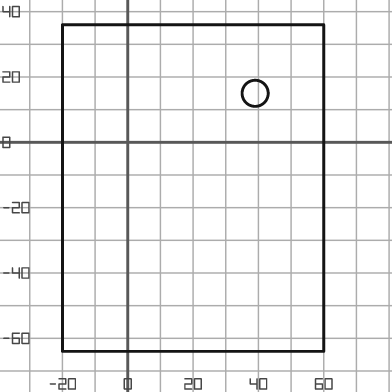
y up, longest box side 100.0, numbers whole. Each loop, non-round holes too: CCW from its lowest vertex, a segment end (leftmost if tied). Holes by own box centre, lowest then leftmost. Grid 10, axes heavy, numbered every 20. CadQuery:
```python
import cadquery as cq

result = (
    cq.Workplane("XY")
    .moveTo(-20.0, -64.0)
    .lineTo(60.0, -64.0)
    .lineTo(60.0, 36.0)
    .lineTo(-20.0, 36.0)
    .close()
    .moveTo(39.0, 15.0)
    .circle(4.0)
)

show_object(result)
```